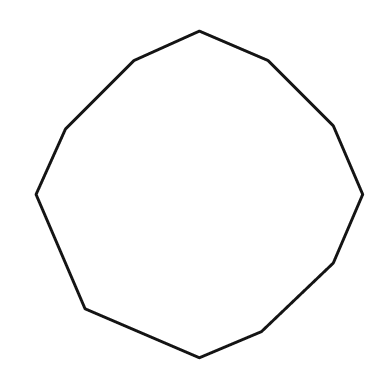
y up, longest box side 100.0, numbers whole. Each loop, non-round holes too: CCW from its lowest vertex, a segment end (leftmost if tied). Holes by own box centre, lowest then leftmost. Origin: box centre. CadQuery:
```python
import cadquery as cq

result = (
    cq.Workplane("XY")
    .moveTo(0.0, -50.0)
    .lineTo(19.0, -42.0)
    .lineTo(41.0, -21.0)
    .lineTo(50.0, 0.0)
    .lineTo(41.0, 21.0)
    .lineTo(21.0, 41.0)
    .lineTo(0.0, 50.0)
    .lineTo(-20.0, 41.0)
    .lineTo(-41.0, 20.0)
    .lineTo(-50.0, 0.0)
    .lineTo(-35.0, -35.0)
    .close()
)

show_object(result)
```